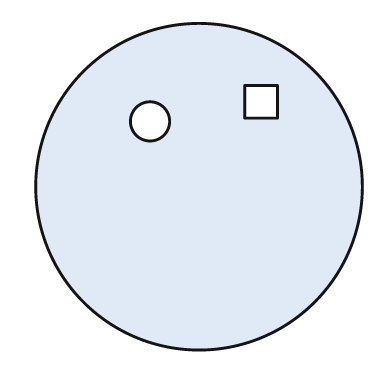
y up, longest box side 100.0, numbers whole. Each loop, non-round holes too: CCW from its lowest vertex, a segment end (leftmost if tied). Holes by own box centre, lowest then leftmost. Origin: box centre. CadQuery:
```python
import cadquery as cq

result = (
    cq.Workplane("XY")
    .moveTo(0.0, 0.0)
    .circle(50.0)
    .moveTo(-15.0, 20.0)
    .circle(6.0)
    .moveTo(14.0, 21.0)
    .lineTo(24.0, 21.0)
    .lineTo(24.0, 31.0)
    .lineTo(14.0, 31.0)
    .close()
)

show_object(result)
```